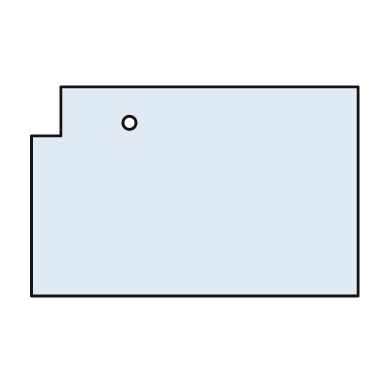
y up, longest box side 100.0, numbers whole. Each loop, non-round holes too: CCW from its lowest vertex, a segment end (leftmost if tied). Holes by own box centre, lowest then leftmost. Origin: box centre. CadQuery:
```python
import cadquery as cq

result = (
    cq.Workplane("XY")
    .moveTo(-50.0, -32.0)
    .lineTo(50.0, -32.0)
    .lineTo(50.0, 32.0)
    .lineTo(-41.0, 32.0)
    .lineTo(-41.0, 17.0)
    .lineTo(-50.0, 17.0)
    .close()
    .moveTo(-20.0, 21.0)
    .circle(2.0)
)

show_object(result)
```